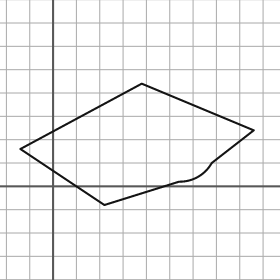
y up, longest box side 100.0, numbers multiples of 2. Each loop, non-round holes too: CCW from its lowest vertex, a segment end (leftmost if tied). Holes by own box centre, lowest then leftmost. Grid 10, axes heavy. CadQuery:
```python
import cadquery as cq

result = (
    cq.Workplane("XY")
    .moveTo(22.0, -8.0)
    .lineTo(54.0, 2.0)
    .threePointArc((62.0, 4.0), (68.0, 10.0))
    .lineTo(86.0, 24.0)
    .lineTo(38.0, 44.0)
    .lineTo(-14.0, 16.0)
    .close()
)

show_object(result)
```